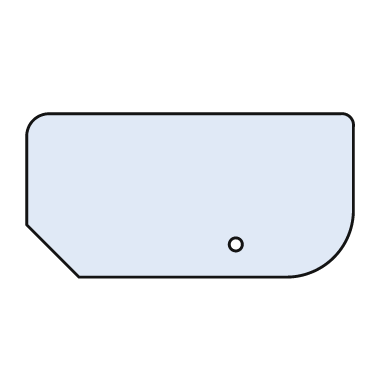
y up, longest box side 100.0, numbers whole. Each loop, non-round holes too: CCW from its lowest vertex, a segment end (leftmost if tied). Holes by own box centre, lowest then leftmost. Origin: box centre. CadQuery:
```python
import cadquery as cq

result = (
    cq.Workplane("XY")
    .moveTo(-34.0, -25.0)
    .lineTo(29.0, -25.0)
    .threePointArc((44.0, -19.0), (50.0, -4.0))
    .lineTo(50.0, 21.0)
    .threePointArc((49.0, 24.0), (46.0, 25.0))
    .lineTo(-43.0, 25.0)
    .threePointArc((-48.0, 23.0), (-50.0, 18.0))
    .lineTo(-50.0, -9.0)
    .close()
    .moveTo(14.0, -15.0)
    .circle(2.0)
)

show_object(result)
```